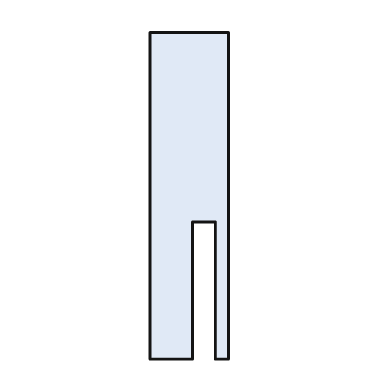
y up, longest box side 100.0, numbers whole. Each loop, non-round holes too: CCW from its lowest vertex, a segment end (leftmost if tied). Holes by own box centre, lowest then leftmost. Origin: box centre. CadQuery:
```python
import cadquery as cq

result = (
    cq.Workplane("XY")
    .moveTo(-12.0, -50.0)
    .lineTo(1.0, -50.0)
    .lineTo(1.0, -8.0)
    .lineTo(8.0, -8.0)
    .lineTo(8.0, -50.0)
    .lineTo(12.0, -50.0)
    .lineTo(12.0, 50.0)
    .lineTo(-12.0, 50.0)
    .close()
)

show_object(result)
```